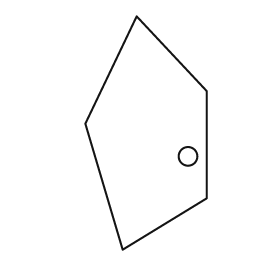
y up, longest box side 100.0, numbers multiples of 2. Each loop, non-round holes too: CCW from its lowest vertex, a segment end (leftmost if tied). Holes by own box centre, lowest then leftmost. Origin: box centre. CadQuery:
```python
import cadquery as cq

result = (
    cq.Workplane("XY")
    .moveTo(-10.0, -50.0)
    .lineTo(26.0, -28.0)
    .lineTo(26.0, 18.0)
    .lineTo(-4.0, 50.0)
    .lineTo(-26.0, 4.0)
    .close()
    .moveTo(18.0, -10.0)
    .circle(4.0)
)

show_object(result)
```